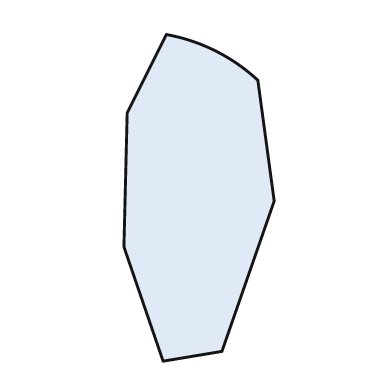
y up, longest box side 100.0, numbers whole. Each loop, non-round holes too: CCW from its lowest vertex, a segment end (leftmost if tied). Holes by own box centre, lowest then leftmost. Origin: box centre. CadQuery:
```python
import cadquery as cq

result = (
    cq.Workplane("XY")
    .moveTo(-11.0, -50.0)
    .lineTo(7.0, -47.0)
    .lineTo(23.0, -1.0)
    .lineTo(18.0, 36.0)
    .threePointArc((5.0, 45.0), (-10.0, 50.0))
    .lineTo(-22.0, 26.0)
    .lineTo(-23.0, -15.0)
    .close()
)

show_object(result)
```